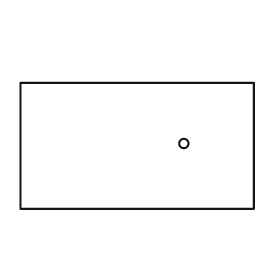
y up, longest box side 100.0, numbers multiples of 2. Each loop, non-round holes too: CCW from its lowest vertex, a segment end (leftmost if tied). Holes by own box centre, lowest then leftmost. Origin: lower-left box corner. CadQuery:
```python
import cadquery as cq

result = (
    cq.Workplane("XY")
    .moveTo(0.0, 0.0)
    .lineTo(100.0, 0.0)
    .lineTo(100.0, 54.0)
    .lineTo(0.0, 54.0)
    .close()
    .moveTo(70.0, 28.0)
    .circle(2.0)
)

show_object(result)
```